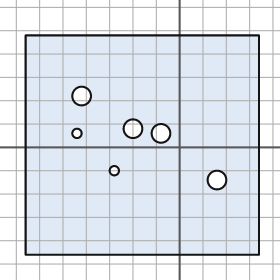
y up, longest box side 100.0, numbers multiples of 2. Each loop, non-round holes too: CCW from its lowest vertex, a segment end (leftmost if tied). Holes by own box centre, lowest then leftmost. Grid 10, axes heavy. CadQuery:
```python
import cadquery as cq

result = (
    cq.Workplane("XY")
    .moveTo(-66.0, -46.0)
    .lineTo(34.0, -46.0)
    .lineTo(34.0, 48.0)
    .lineTo(-66.0, 48.0)
    .close()
    .moveTo(16.0, -14.0)
    .circle(4.0)
    .moveTo(-28.0, -10.0)
    .circle(2.0)
    .moveTo(-44.0, 6.0)
    .circle(2.0)
    .moveTo(-8.0, 6.0)
    .circle(4.0)
    .moveTo(-20.0, 8.0)
    .circle(4.0)
    .moveTo(-42.0, 22.0)
    .circle(4.0)
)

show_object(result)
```